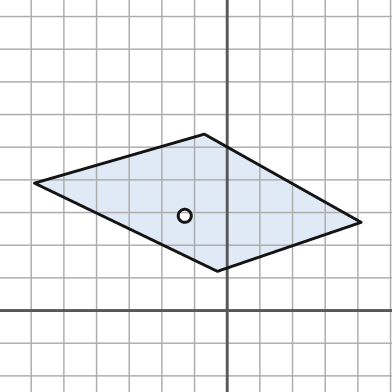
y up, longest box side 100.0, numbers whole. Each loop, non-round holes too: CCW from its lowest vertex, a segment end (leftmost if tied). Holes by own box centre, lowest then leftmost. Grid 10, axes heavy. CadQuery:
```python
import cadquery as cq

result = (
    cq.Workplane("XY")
    .moveTo(-3.0, 12.0)
    .lineTo(41.0, 27.0)
    .lineTo(-7.0, 54.0)
    .lineTo(-59.0, 39.0)
    .close()
    .moveTo(-13.0, 29.0)
    .circle(2.0)
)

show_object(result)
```